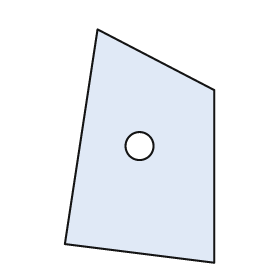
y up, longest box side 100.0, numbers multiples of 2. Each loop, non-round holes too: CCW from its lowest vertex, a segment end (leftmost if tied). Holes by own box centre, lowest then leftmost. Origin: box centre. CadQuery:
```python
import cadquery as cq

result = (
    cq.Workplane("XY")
    .moveTo(32.0, -50.0)
    .lineTo(32.0, 24.0)
    .lineTo(-18.0, 50.0)
    .lineTo(-32.0, -42.0)
    .close()
    .moveTo(0.0, 0.0)
    .circle(6.0)
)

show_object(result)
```